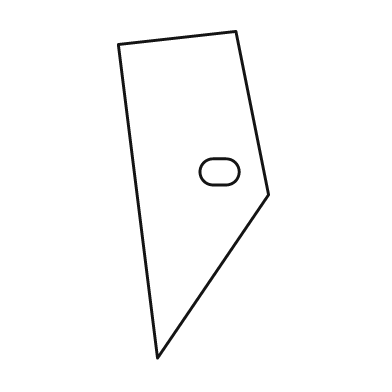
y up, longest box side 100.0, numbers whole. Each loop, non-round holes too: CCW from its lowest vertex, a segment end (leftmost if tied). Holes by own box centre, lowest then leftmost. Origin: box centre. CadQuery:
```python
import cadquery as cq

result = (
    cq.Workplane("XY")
    .moveTo(-11.0, -50.0)
    .lineTo(23.0, 0.0)
    .lineTo(13.0, 50.0)
    .lineTo(-23.0, 46.0)
    .close()
    .moveTo(6.0, 3.0)
    .lineTo(10.0, 3.0)
    .threePointArc((14.0, 7.0), (10.0, 11.0))
    .lineTo(6.0, 11.0)
    .threePointArc((2.0, 7.0), (6.0, 3.0))
    .close()
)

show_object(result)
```